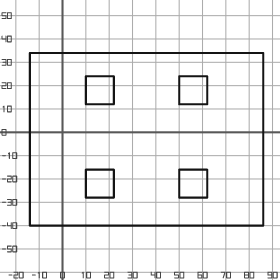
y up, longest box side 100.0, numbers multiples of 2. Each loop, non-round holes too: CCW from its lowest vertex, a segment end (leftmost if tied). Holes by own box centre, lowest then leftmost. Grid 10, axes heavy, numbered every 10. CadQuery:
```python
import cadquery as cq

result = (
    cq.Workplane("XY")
    .moveTo(-14.0, -40.0)
    .lineTo(86.0, -40.0)
    .lineTo(86.0, 34.0)
    .lineTo(-14.0, 34.0)
    .close()
    .moveTo(10.0, -28.0)
    .lineTo(22.0, -28.0)
    .lineTo(22.0, -16.0)
    .lineTo(10.0, -16.0)
    .close()
    .moveTo(50.0, -28.0)
    .lineTo(62.0, -28.0)
    .lineTo(62.0, -16.0)
    .lineTo(50.0, -16.0)
    .close()
    .moveTo(10.0, 12.0)
    .lineTo(22.0, 12.0)
    .lineTo(22.0, 24.0)
    .lineTo(10.0, 24.0)
    .close()
    .moveTo(50.0, 12.0)
    .lineTo(62.0, 12.0)
    .lineTo(62.0, 24.0)
    .lineTo(50.0, 24.0)
    .close()
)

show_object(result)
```